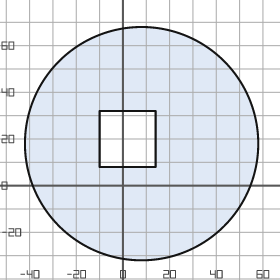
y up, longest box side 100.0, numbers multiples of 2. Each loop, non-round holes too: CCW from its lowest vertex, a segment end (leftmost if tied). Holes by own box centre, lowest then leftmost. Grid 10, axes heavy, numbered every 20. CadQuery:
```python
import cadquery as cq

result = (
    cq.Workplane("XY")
    .moveTo(8.0, 18.0)
    .circle(50.0)
    .moveTo(-10.0, 8.0)
    .lineTo(14.0, 8.0)
    .lineTo(14.0, 32.0)
    .lineTo(-10.0, 32.0)
    .close()
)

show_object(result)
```